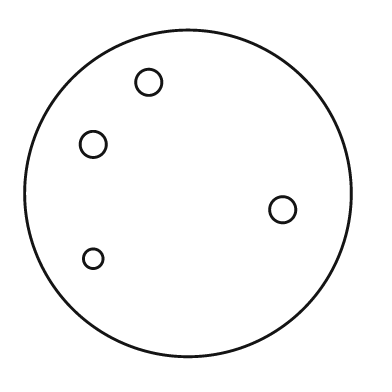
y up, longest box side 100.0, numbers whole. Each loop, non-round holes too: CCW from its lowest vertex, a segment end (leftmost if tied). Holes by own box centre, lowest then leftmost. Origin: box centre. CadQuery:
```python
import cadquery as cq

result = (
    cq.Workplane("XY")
    .moveTo(0.0, 0.0)
    .circle(50.0)
    .moveTo(-29.0, -20.0)
    .circle(3.0)
    .moveTo(29.0, -5.0)
    .circle(4.0)
    .moveTo(-29.0, 15.0)
    .circle(4.0)
    .moveTo(-12.0, 34.0)
    .circle(4.0)
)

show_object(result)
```